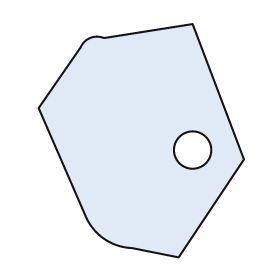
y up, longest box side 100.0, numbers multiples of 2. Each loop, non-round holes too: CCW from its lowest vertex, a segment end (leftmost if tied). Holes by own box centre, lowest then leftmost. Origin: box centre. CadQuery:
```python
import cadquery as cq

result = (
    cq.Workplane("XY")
    .moveTo(16.0, -50.0)
    .lineTo(44.0, -8.0)
    .lineTo(22.0, 50.0)
    .lineTo(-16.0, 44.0)
    .threePointArc((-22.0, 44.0), (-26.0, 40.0))
    .lineTo(-44.0, 14.0)
    .lineTo(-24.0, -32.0)
    .threePointArc((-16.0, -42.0), (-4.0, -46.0))
    .close()
    .moveTo(22.0, -4.0)
    .circle(8.0)
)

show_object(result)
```